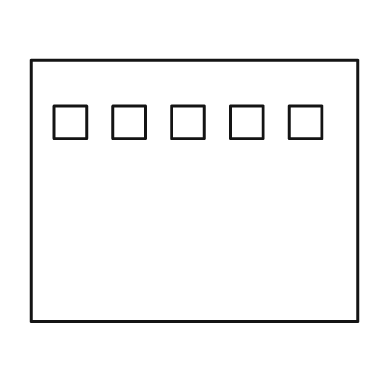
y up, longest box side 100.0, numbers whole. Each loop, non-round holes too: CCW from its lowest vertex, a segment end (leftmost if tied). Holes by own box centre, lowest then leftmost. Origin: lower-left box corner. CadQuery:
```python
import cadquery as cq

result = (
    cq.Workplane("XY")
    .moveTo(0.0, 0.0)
    .lineTo(100.0, 0.0)
    .lineTo(100.0, 80.0)
    .lineTo(0.0, 80.0)
    .close()
    .moveTo(7.0, 56.0)
    .lineTo(17.0, 56.0)
    .lineTo(17.0, 66.0)
    .lineTo(7.0, 66.0)
    .close()
    .moveTo(25.0, 56.0)
    .lineTo(35.0, 56.0)
    .lineTo(35.0, 66.0)
    .lineTo(25.0, 66.0)
    .close()
    .moveTo(43.0, 56.0)
    .lineTo(53.0, 56.0)
    .lineTo(53.0, 66.0)
    .lineTo(43.0, 66.0)
    .close()
    .moveTo(61.0, 56.0)
    .lineTo(71.0, 56.0)
    .lineTo(71.0, 66.0)
    .lineTo(61.0, 66.0)
    .close()
    .moveTo(79.0, 56.0)
    .lineTo(89.0, 56.0)
    .lineTo(89.0, 66.0)
    .lineTo(79.0, 66.0)
    .close()
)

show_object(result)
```